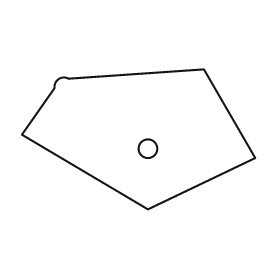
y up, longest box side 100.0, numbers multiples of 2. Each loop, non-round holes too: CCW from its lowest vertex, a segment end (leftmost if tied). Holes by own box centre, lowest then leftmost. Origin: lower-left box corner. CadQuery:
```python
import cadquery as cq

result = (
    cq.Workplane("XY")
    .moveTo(54.0, 0.0)
    .lineTo(100.0, 22.0)
    .lineTo(78.0, 60.0)
    .lineTo(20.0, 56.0)
    .threePointArc((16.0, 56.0), (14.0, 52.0))
    .lineTo(0.0, 32.0)
    .close()
    .moveTo(54.0, 26.0)
    .circle(4.0)
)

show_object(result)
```